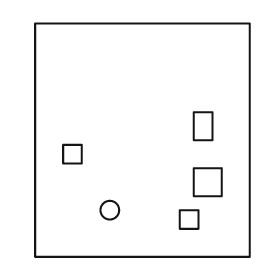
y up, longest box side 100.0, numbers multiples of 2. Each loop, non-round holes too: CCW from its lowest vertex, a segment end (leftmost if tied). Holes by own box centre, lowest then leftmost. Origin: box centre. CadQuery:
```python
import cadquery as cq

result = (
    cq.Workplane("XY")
    .moveTo(-46.0, -50.0)
    .lineTo(46.0, -50.0)
    .lineTo(46.0, 50.0)
    .lineTo(-46.0, 50.0)
    .close()
    .moveTo(16.0, -38.0)
    .lineTo(24.0, -38.0)
    .lineTo(24.0, -30.0)
    .lineTo(16.0, -30.0)
    .close()
    .moveTo(-14.0, -30.0)
    .circle(4.0)
    .moveTo(22.0, -24.0)
    .lineTo(34.0, -24.0)
    .lineTo(34.0, -12.0)
    .lineTo(22.0, -12.0)
    .close()
    .moveTo(-34.0, -10.0)
    .lineTo(-26.0, -10.0)
    .lineTo(-26.0, -2.0)
    .lineTo(-34.0, -2.0)
    .close()
    .moveTo(22.0, 0.0)
    .lineTo(30.0, 0.0)
    .lineTo(30.0, 12.0)
    .lineTo(22.0, 12.0)
    .close()
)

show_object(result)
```